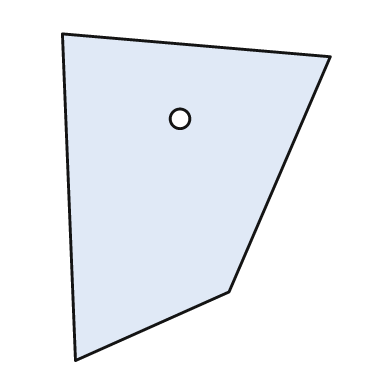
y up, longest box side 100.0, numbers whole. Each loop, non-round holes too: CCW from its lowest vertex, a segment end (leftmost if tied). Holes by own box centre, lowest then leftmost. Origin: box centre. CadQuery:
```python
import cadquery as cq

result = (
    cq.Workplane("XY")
    .moveTo(-37.0, -50.0)
    .lineTo(10.0, -29.0)
    .lineTo(41.0, 43.0)
    .lineTo(-41.0, 50.0)
    .close()
    .moveTo(-5.0, 24.0)
    .circle(3.0)
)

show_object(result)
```